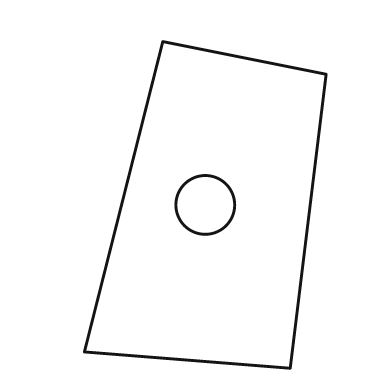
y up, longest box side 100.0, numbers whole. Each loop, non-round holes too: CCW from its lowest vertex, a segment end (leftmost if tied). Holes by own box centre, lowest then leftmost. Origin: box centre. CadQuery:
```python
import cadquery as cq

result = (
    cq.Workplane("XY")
    .moveTo(26.0, -50.0)
    .lineTo(37.0, 40.0)
    .lineTo(-13.0, 50.0)
    .lineTo(-37.0, -45.0)
    .close()
    .moveTo(0.0, 0.0)
    .circle(9.0)
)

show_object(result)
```